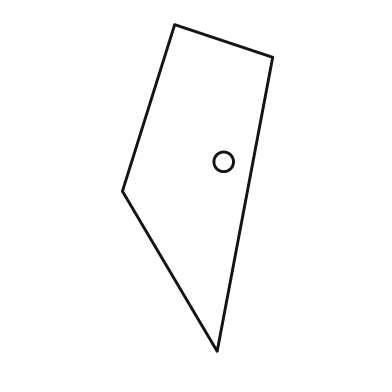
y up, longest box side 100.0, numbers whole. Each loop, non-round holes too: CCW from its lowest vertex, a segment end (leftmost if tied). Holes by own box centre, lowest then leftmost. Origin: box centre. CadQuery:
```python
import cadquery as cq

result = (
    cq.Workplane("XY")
    .moveTo(6.0, -50.0)
    .lineTo(23.0, 40.0)
    .lineTo(-7.0, 50.0)
    .lineTo(-23.0, -1.0)
    .close()
    .moveTo(8.0, 8.0)
    .circle(3.0)
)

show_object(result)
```